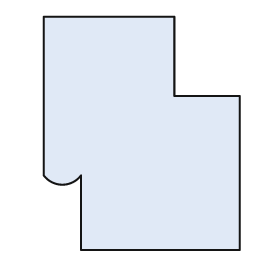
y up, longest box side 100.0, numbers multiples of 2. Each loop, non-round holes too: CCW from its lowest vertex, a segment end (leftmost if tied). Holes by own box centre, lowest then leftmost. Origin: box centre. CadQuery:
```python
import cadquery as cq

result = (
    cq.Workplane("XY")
    .moveTo(-26.0, -50.0)
    .lineTo(42.0, -50.0)
    .lineTo(42.0, 16.0)
    .lineTo(14.0, 16.0)
    .lineTo(14.0, 50.0)
    .lineTo(-42.0, 50.0)
    .lineTo(-42.0, -18.0)
    .threePointArc((-34.0, -22.0), (-26.0, -18.0))
    .close()
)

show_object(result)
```